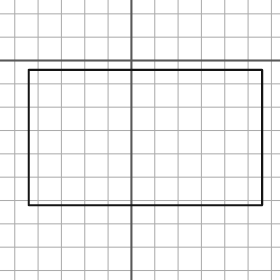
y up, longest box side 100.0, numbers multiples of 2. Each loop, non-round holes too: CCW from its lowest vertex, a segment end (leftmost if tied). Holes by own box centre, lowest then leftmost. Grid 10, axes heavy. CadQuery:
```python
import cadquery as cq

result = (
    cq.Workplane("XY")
    .moveTo(-44.0, -62.0)
    .lineTo(56.0, -62.0)
    .lineTo(56.0, -4.0)
    .lineTo(-44.0, -4.0)
    .close()
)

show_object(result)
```